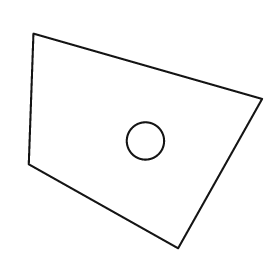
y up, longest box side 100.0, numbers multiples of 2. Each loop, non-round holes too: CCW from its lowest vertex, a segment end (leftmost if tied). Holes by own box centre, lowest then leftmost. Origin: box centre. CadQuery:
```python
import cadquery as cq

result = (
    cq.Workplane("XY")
    .moveTo(14.0, -46.0)
    .lineTo(50.0, 18.0)
    .lineTo(-48.0, 46.0)
    .lineTo(-50.0, -10.0)
    .close()
    .moveTo(0.0, 0.0)
    .circle(8.0)
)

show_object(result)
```